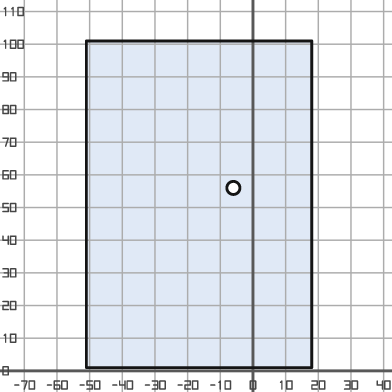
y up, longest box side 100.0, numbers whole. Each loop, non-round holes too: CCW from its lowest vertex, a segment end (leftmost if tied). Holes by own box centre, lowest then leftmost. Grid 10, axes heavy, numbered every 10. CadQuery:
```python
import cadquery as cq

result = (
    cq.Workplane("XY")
    .moveTo(-51.0, 1.0)
    .lineTo(18.0, 1.0)
    .lineTo(18.0, 101.0)
    .lineTo(-51.0, 101.0)
    .close()
    .moveTo(-6.0, 56.0)
    .circle(2.0)
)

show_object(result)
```